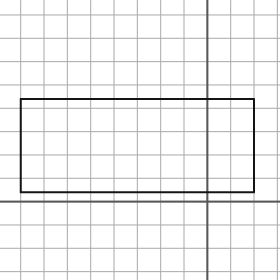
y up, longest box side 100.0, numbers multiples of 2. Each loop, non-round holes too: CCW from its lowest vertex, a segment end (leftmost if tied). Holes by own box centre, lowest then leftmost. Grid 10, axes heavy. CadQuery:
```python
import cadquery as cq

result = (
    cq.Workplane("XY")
    .moveTo(-80.0, 4.0)
    .lineTo(20.0, 4.0)
    .lineTo(20.0, 44.0)
    .lineTo(-80.0, 44.0)
    .close()
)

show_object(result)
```